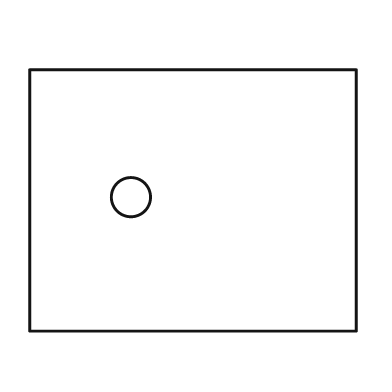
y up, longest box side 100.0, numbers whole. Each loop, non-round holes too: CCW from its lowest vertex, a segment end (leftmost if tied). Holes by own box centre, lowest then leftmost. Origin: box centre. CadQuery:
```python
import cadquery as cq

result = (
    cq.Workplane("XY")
    .moveTo(-50.0, -40.0)
    .lineTo(50.0, -40.0)
    .lineTo(50.0, 40.0)
    .lineTo(-50.0, 40.0)
    .close()
    .moveTo(-19.0, 1.0)
    .circle(6.0)
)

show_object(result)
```